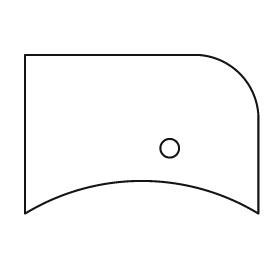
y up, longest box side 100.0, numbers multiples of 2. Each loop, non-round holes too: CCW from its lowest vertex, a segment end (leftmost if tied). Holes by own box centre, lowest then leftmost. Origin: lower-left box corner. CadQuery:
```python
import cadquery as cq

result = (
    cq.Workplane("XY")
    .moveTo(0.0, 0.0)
    .threePointArc((50.0, 14.0), (100.0, 0.0))
    .lineTo(100.0, 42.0)
    .threePointArc((92.0, 60.0), (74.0, 68.0))
    .lineTo(0.0, 68.0)
    .close()
    .moveTo(62.0, 28.0)
    .circle(4.0)
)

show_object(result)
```